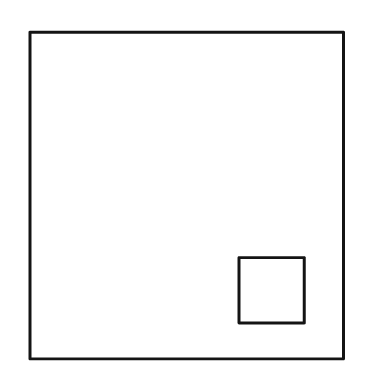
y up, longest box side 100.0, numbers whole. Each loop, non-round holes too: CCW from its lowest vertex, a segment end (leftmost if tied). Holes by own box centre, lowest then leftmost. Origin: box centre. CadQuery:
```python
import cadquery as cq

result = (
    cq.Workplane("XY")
    .moveTo(-48.0, -50.0)
    .lineTo(48.0, -50.0)
    .lineTo(48.0, 50.0)
    .lineTo(-48.0, 50.0)
    .close()
    .moveTo(16.0, -39.0)
    .lineTo(36.0, -39.0)
    .lineTo(36.0, -19.0)
    .lineTo(16.0, -19.0)
    .close()
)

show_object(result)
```